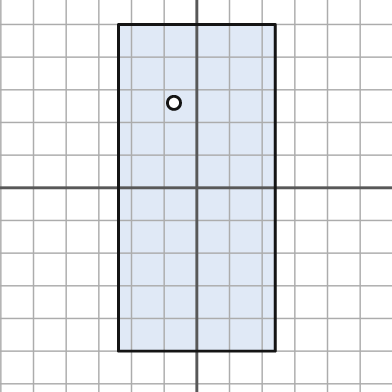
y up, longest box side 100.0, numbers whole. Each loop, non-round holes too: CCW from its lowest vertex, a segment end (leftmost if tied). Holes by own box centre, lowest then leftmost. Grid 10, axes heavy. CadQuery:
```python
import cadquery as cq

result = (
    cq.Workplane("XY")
    .moveTo(-24.0, -50.0)
    .lineTo(24.0, -50.0)
    .lineTo(24.0, 50.0)
    .lineTo(-24.0, 50.0)
    .close()
    .moveTo(-7.0, 26.0)
    .circle(2.0)
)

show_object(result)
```